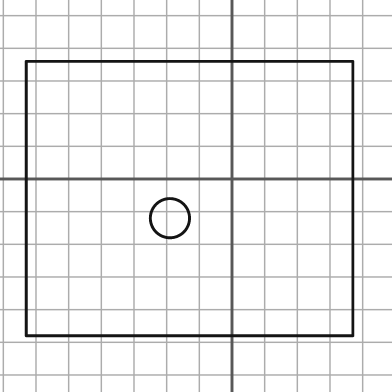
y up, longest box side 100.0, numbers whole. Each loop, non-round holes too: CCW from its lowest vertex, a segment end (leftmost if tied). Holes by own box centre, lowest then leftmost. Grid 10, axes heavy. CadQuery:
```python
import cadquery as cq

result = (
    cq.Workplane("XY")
    .moveTo(-63.0, -48.0)
    .lineTo(37.0, -48.0)
    .lineTo(37.0, 36.0)
    .lineTo(-63.0, 36.0)
    .close()
    .moveTo(-19.0, -12.0)
    .circle(6.0)
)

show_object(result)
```